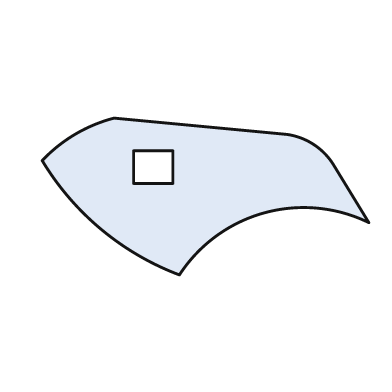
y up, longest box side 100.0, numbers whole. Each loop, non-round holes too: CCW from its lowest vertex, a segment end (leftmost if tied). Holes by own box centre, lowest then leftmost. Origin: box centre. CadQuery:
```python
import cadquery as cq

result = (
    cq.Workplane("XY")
    .moveTo(-8.0, -24.0)
    .threePointArc((18.0, -5.0), (50.0, -8.0))
    .lineTo(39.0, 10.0)
    .threePointArc((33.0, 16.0), (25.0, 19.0))
    .lineTo(-28.0, 24.0)
    .threePointArc((-40.0, 19.0), (-50.0, 11.0))
    .threePointArc((-32.0, -10.0), (-8.0, -24.0))
    .close()
    .moveTo(-22.0, 4.0)
    .lineTo(-10.0, 4.0)
    .lineTo(-10.0, 14.0)
    .lineTo(-22.0, 14.0)
    .close()
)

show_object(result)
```